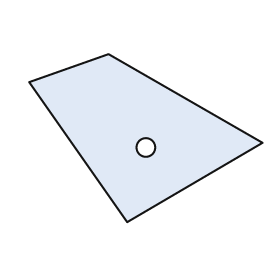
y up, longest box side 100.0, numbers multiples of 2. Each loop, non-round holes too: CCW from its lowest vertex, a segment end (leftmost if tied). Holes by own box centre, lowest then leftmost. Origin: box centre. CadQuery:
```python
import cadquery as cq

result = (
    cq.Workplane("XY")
    .moveTo(-8.0, -36.0)
    .lineTo(50.0, -2.0)
    .lineTo(-16.0, 36.0)
    .lineTo(-50.0, 24.0)
    .close()
    .moveTo(0.0, -4.0)
    .circle(4.0)
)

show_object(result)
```